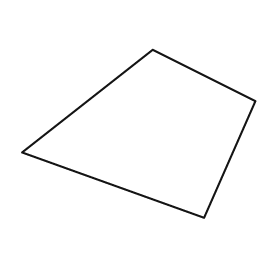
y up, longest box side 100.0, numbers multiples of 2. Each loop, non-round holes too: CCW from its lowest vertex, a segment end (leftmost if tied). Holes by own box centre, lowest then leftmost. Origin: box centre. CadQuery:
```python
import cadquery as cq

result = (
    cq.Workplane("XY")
    .moveTo(28.0, -36.0)
    .lineTo(50.0, 14.0)
    .lineTo(6.0, 36.0)
    .lineTo(-50.0, -8.0)
    .close()
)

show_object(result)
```